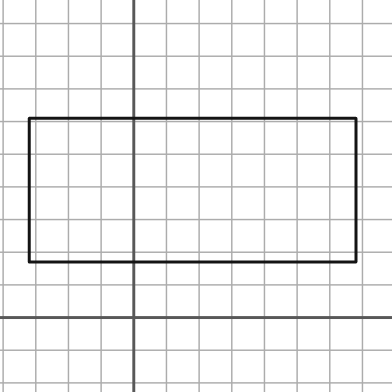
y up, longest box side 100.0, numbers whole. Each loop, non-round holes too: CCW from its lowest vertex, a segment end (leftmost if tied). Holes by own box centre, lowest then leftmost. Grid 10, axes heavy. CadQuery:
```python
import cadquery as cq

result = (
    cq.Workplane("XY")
    .moveTo(-32.0, 17.0)
    .lineTo(68.0, 17.0)
    .lineTo(68.0, 61.0)
    .lineTo(-32.0, 61.0)
    .close()
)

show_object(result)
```